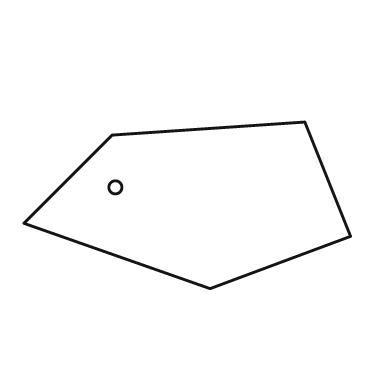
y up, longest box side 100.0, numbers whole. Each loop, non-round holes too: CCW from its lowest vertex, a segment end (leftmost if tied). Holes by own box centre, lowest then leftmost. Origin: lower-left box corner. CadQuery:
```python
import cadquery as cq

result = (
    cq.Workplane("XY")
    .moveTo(57.0, 0.0)
    .lineTo(100.0, 16.0)
    .lineTo(86.0, 51.0)
    .lineTo(27.0, 47.0)
    .lineTo(0.0, 20.0)
    .close()
    .moveTo(28.0, 31.0)
    .circle(2.0)
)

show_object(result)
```